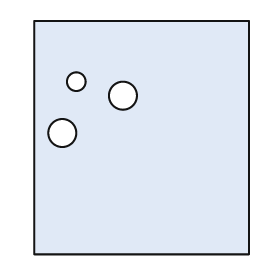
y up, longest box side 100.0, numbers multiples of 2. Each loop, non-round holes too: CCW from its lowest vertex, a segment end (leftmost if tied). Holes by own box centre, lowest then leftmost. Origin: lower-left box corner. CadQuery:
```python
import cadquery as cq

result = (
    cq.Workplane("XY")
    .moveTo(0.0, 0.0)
    .lineTo(92.0, 0.0)
    .lineTo(92.0, 100.0)
    .lineTo(0.0, 100.0)
    .close()
    .moveTo(12.0, 52.0)
    .circle(6.0)
    .moveTo(38.0, 68.0)
    .circle(6.0)
    .moveTo(18.0, 74.0)
    .circle(4.0)
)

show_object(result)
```